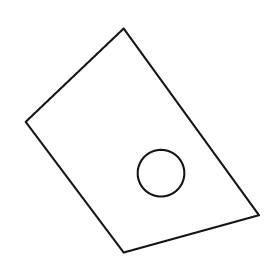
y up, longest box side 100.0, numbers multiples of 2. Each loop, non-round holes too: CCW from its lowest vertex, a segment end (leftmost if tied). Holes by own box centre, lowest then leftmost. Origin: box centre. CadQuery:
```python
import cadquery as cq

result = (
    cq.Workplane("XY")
    .moveTo(-8.0, -48.0)
    .lineTo(50.0, -32.0)
    .lineTo(-8.0, 48.0)
    .lineTo(-50.0, 8.0)
    .close()
    .moveTo(8.0, -14.0)
    .circle(10.0)
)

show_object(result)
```